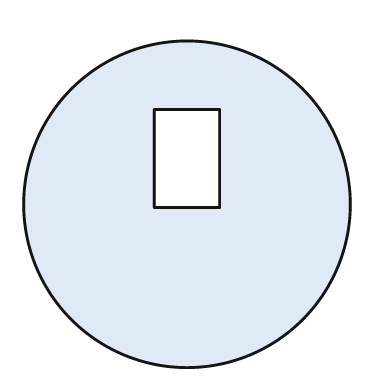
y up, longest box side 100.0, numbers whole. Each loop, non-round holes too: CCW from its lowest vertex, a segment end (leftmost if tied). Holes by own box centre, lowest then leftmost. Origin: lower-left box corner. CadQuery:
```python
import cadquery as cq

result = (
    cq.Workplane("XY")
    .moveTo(50.0, 50.0)
    .circle(50.0)
    .moveTo(40.0, 49.0)
    .lineTo(60.0, 49.0)
    .lineTo(60.0, 79.0)
    .lineTo(40.0, 79.0)
    .close()
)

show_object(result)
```